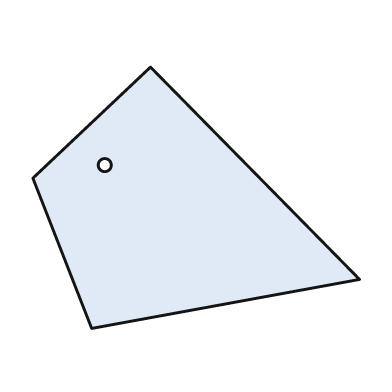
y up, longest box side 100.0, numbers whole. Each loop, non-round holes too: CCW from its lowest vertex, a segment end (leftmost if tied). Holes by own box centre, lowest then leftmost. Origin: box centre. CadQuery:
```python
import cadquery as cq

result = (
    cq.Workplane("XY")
    .moveTo(-32.0, -40.0)
    .lineTo(50.0, -25.0)
    .lineTo(-14.0, 40.0)
    .lineTo(-50.0, 6.0)
    .close()
    .moveTo(-28.0, 10.0)
    .circle(2.0)
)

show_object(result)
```